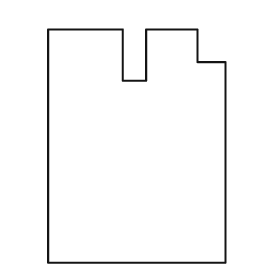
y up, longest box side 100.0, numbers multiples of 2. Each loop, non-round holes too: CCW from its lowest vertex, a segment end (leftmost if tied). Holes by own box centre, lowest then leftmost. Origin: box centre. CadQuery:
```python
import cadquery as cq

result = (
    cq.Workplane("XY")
    .moveTo(-38.0, -50.0)
    .lineTo(38.0, -50.0)
    .lineTo(38.0, 36.0)
    .lineTo(26.0, 36.0)
    .lineTo(26.0, 50.0)
    .lineTo(4.0, 50.0)
    .lineTo(4.0, 28.0)
    .lineTo(-6.0, 28.0)
    .lineTo(-6.0, 50.0)
    .lineTo(-38.0, 50.0)
    .close()
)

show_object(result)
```